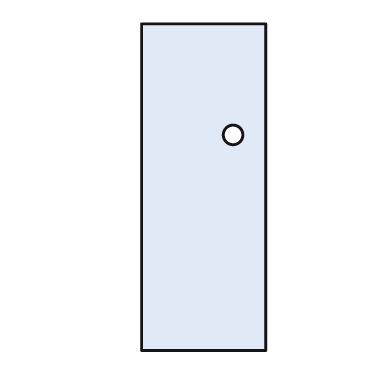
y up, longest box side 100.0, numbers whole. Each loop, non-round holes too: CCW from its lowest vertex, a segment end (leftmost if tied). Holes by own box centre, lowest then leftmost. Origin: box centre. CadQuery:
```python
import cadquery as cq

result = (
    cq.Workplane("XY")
    .moveTo(-19.0, -50.0)
    .lineTo(19.0, -50.0)
    .lineTo(19.0, 50.0)
    .lineTo(-19.0, 50.0)
    .close()
    .moveTo(9.0, 16.0)
    .circle(3.0)
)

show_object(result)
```